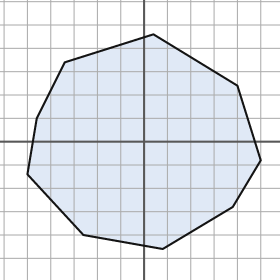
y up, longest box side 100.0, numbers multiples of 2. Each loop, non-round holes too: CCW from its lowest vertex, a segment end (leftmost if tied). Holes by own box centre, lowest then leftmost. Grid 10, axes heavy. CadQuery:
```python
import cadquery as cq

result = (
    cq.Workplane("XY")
    .moveTo(8.0, -46.0)
    .lineTo(38.0, -28.0)
    .lineTo(50.0, -8.0)
    .lineTo(40.0, 24.0)
    .lineTo(4.0, 46.0)
    .lineTo(-34.0, 34.0)
    .lineTo(-46.0, 10.0)
    .lineTo(-50.0, -14.0)
    .lineTo(-26.0, -40.0)
    .close()
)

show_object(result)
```